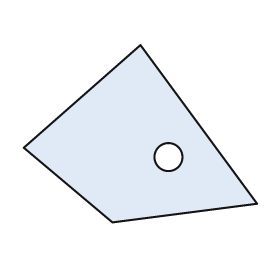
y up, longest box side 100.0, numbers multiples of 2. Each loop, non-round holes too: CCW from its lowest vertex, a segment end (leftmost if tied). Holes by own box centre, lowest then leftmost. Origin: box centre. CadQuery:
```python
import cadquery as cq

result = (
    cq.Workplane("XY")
    .moveTo(-12.0, -38.0)
    .lineTo(50.0, -30.0)
    .lineTo(0.0, 38.0)
    .lineTo(-50.0, -6.0)
    .close()
    .moveTo(12.0, -10.0)
    .circle(6.0)
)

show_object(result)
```